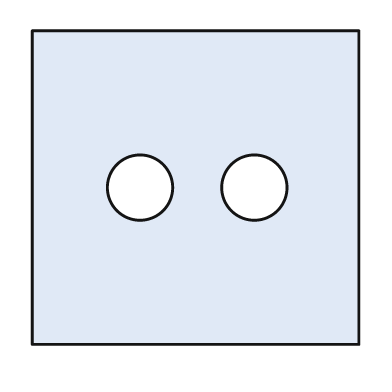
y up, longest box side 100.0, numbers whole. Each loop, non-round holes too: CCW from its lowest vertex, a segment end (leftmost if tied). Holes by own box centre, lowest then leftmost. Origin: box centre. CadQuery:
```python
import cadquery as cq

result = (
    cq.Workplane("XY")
    .moveTo(-50.0, -48.0)
    .lineTo(50.0, -48.0)
    .lineTo(50.0, 48.0)
    .lineTo(-50.0, 48.0)
    .close()
    .moveTo(-17.0, 0.0)
    .circle(10.0)
    .moveTo(18.0, 0.0)
    .circle(10.0)
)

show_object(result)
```